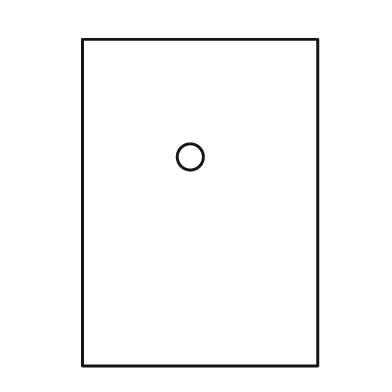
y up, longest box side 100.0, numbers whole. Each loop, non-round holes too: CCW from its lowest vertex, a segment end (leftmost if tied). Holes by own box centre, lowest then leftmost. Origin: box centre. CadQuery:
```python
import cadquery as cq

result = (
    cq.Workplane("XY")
    .moveTo(-36.0, -50.0)
    .lineTo(36.0, -50.0)
    .lineTo(36.0, 50.0)
    .lineTo(-36.0, 50.0)
    .close()
    .moveTo(-3.0, 14.0)
    .circle(4.0)
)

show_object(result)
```